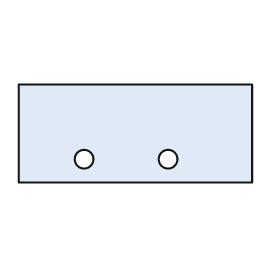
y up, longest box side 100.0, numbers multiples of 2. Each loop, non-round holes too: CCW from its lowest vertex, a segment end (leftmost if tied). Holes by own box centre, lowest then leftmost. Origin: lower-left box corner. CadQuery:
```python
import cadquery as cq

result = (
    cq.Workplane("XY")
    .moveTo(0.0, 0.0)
    .lineTo(100.0, 0.0)
    .lineTo(100.0, 42.0)
    .lineTo(0.0, 42.0)
    .close()
    .moveTo(28.0, 10.0)
    .circle(4.0)
    .moveTo(64.0, 10.0)
    .circle(4.0)
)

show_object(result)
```